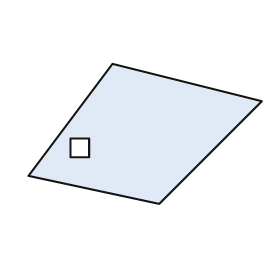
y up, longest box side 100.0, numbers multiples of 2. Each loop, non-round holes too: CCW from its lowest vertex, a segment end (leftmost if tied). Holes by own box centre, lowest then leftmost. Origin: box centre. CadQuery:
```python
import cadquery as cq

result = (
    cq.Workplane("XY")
    .moveTo(6.0, -30.0)
    .lineTo(50.0, 14.0)
    .lineTo(-14.0, 30.0)
    .lineTo(-50.0, -18.0)
    .close()
    .moveTo(-32.0, -10.0)
    .lineTo(-24.0, -10.0)
    .lineTo(-24.0, -2.0)
    .lineTo(-32.0, -2.0)
    .close()
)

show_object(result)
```